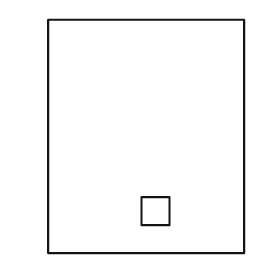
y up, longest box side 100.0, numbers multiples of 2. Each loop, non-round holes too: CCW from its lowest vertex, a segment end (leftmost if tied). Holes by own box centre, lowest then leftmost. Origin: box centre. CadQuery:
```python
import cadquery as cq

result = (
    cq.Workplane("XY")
    .moveTo(-42.0, -50.0)
    .lineTo(42.0, -50.0)
    .lineTo(42.0, 50.0)
    .lineTo(-42.0, 50.0)
    .close()
    .moveTo(-2.0, -38.0)
    .lineTo(10.0, -38.0)
    .lineTo(10.0, -26.0)
    .lineTo(-2.0, -26.0)
    .close()
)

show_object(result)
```